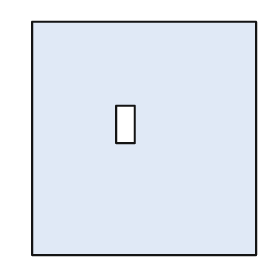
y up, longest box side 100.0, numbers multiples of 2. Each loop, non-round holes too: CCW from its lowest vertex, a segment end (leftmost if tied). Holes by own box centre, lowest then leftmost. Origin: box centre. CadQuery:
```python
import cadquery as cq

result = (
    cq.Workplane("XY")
    .moveTo(-48.0, -50.0)
    .lineTo(48.0, -50.0)
    .lineTo(48.0, 50.0)
    .lineTo(-48.0, 50.0)
    .close()
    .moveTo(-12.0, -2.0)
    .lineTo(-4.0, -2.0)
    .lineTo(-4.0, 14.0)
    .lineTo(-12.0, 14.0)
    .close()
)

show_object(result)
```